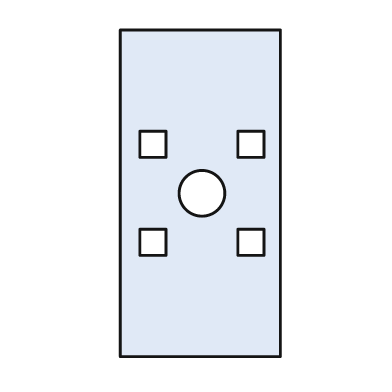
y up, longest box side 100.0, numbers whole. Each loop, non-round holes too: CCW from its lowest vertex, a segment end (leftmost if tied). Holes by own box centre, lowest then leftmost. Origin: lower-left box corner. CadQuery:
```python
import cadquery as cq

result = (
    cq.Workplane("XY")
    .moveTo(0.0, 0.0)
    .lineTo(49.0, 0.0)
    .lineTo(49.0, 100.0)
    .lineTo(0.0, 100.0)
    .close()
    .moveTo(6.0, 31.0)
    .lineTo(14.0, 31.0)
    .lineTo(14.0, 39.0)
    .lineTo(6.0, 39.0)
    .close()
    .moveTo(36.0, 31.0)
    .lineTo(44.0, 31.0)
    .lineTo(44.0, 39.0)
    .lineTo(36.0, 39.0)
    .close()
    .moveTo(25.0, 50.0)
    .circle(7.0)
    .moveTo(6.0, 61.0)
    .lineTo(14.0, 61.0)
    .lineTo(14.0, 69.0)
    .lineTo(6.0, 69.0)
    .close()
    .moveTo(36.0, 61.0)
    .lineTo(44.0, 61.0)
    .lineTo(44.0, 69.0)
    .lineTo(36.0, 69.0)
    .close()
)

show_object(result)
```